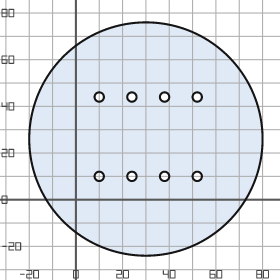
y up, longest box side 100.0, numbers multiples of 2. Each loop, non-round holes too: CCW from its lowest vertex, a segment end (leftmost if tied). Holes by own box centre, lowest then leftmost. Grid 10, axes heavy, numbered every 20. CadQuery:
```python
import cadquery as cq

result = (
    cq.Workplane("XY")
    .moveTo(30.0, 26.0)
    .circle(50.0)
    .moveTo(10.0, 10.0)
    .circle(2.0)
    .moveTo(24.0, 10.0)
    .circle(2.0)
    .moveTo(38.0, 10.0)
    .circle(2.0)
    .moveTo(52.0, 10.0)
    .circle(2.0)
    .moveTo(10.0, 44.0)
    .circle(2.0)
    .moveTo(24.0, 44.0)
    .circle(2.0)
    .moveTo(38.0, 44.0)
    .circle(2.0)
    .moveTo(52.0, 44.0)
    .circle(2.0)
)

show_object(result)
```